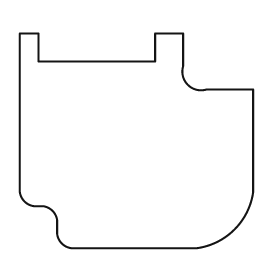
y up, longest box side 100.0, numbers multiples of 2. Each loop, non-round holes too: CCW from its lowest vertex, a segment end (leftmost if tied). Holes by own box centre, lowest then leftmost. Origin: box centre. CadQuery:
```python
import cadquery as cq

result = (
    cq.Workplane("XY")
    .moveTo(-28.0, -46.0)
    .lineTo(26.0, -46.0)
    .threePointArc((42.0, -38.0), (50.0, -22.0))
    .lineTo(50.0, 22.0)
    .lineTo(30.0, 22.0)
    .threePointArc((22.0, 24.0), (20.0, 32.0))
    .lineTo(20.0, 46.0)
    .lineTo(8.0, 46.0)
    .lineTo(8.0, 34.0)
    .lineTo(-42.0, 34.0)
    .lineTo(-42.0, 46.0)
    .lineTo(-50.0, 46.0)
    .lineTo(-50.0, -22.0)
    .threePointArc((-48.0, -26.0), (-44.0, -28.0))
    .lineTo(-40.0, -28.0)
    .threePointArc((-36.0, -30.0), (-34.0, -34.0))
    .lineTo(-34.0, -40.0)
    .threePointArc((-32.0, -44.0), (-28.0, -46.0))
    .close()
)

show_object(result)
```